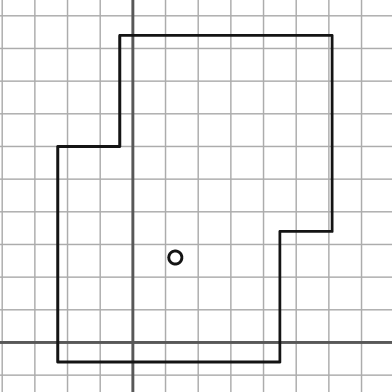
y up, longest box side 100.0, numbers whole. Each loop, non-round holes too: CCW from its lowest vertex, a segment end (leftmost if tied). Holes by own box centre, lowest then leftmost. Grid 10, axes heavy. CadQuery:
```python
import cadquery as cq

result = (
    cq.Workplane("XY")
    .moveTo(-23.0, -6.0)
    .lineTo(45.0, -6.0)
    .lineTo(45.0, 34.0)
    .lineTo(61.0, 34.0)
    .lineTo(61.0, 94.0)
    .lineTo(-4.0, 94.0)
    .lineTo(-4.0, 60.0)
    .lineTo(-23.0, 60.0)
    .close()
    .moveTo(13.0, 26.0)
    .circle(2.0)
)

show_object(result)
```